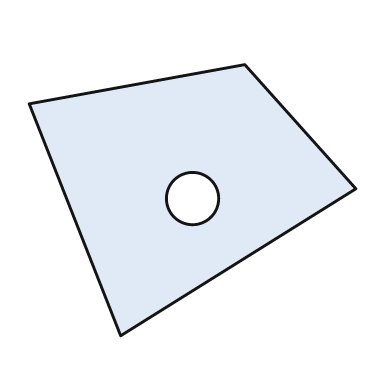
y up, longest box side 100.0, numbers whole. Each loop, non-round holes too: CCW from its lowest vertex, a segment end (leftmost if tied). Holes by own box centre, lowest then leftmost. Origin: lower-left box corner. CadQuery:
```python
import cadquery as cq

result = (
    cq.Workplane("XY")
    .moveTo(28.0, 0.0)
    .lineTo(100.0, 45.0)
    .lineTo(66.0, 83.0)
    .lineTo(0.0, 71.0)
    .close()
    .moveTo(50.0, 42.0)
    .circle(8.0)
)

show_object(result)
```